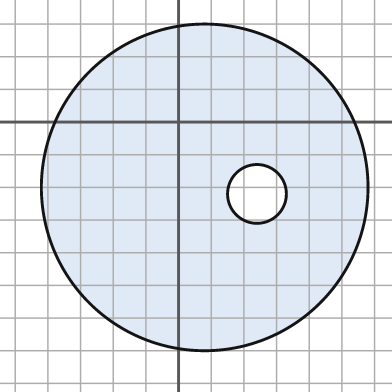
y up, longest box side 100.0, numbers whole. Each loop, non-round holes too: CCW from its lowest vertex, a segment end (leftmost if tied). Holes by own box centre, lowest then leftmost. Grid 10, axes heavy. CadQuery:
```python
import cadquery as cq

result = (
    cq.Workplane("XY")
    .moveTo(8.0, -20.0)
    .circle(50.0)
    .moveTo(24.0, -22.0)
    .circle(9.0)
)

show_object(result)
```